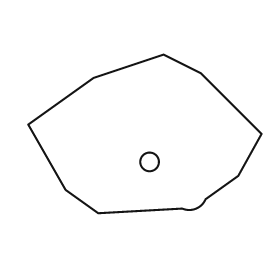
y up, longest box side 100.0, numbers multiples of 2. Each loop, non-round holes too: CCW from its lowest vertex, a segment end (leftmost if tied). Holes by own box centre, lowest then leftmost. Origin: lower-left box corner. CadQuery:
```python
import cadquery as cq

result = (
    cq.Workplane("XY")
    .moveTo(30.0, 0.0)
    .lineTo(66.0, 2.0)
    .threePointArc((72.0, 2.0), (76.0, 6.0))
    .lineTo(90.0, 16.0)
    .lineTo(100.0, 34.0)
    .lineTo(74.0, 60.0)
    .lineTo(58.0, 68.0)
    .lineTo(28.0, 58.0)
    .lineTo(0.0, 38.0)
    .lineTo(16.0, 10.0)
    .close()
    .moveTo(52.0, 22.0)
    .circle(4.0)
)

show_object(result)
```